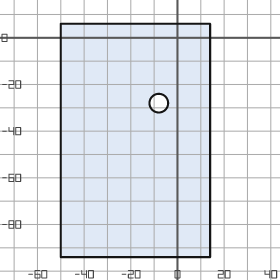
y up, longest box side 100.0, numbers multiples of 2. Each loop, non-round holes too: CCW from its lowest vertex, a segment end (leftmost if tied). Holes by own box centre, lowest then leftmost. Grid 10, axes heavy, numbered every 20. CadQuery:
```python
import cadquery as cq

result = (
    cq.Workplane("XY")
    .moveTo(-50.0, -94.0)
    .lineTo(14.0, -94.0)
    .lineTo(14.0, 6.0)
    .lineTo(-50.0, 6.0)
    .close()
    .moveTo(-8.0, -28.0)
    .circle(4.0)
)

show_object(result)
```